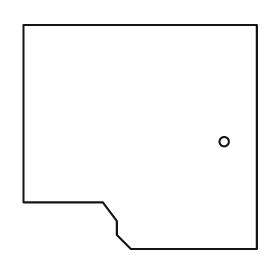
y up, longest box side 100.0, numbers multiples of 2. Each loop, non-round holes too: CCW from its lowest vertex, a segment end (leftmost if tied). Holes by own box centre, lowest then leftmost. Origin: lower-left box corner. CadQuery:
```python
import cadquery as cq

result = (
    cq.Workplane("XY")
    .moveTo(46.0, 0.0)
    .lineTo(100.0, 0.0)
    .lineTo(100.0, 96.0)
    .lineTo(0.0, 96.0)
    .lineTo(0.0, 20.0)
    .lineTo(34.0, 20.0)
    .lineTo(40.0, 12.0)
    .lineTo(40.0, 6.0)
    .close()
    .moveTo(86.0, 46.0)
    .circle(2.0)
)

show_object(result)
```